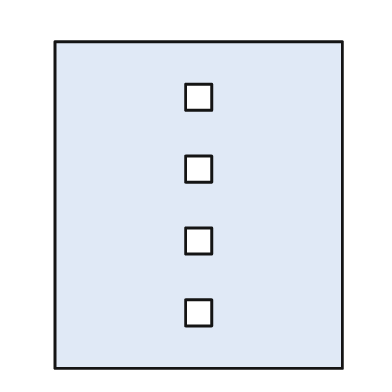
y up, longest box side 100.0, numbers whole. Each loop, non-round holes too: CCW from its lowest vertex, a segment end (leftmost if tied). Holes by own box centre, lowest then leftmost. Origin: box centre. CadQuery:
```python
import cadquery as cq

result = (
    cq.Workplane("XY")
    .moveTo(-44.0, -50.0)
    .lineTo(44.0, -50.0)
    .lineTo(44.0, 50.0)
    .lineTo(-44.0, 50.0)
    .close()
    .moveTo(-4.0, -37.0)
    .lineTo(4.0, -37.0)
    .lineTo(4.0, -29.0)
    .lineTo(-4.0, -29.0)
    .close()
    .moveTo(-4.0, -15.0)
    .lineTo(4.0, -15.0)
    .lineTo(4.0, -7.0)
    .lineTo(-4.0, -7.0)
    .close()
    .moveTo(-4.0, 7.0)
    .lineTo(4.0, 7.0)
    .lineTo(4.0, 15.0)
    .lineTo(-4.0, 15.0)
    .close()
    .moveTo(-4.0, 29.0)
    .lineTo(4.0, 29.0)
    .lineTo(4.0, 37.0)
    .lineTo(-4.0, 37.0)
    .close()
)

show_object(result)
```